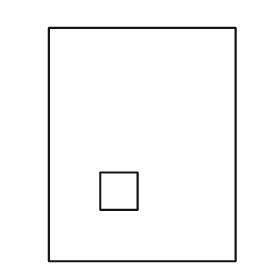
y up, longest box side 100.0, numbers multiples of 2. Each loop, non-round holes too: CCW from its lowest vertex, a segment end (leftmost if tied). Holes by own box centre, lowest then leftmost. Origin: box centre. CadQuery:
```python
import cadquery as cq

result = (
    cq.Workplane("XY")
    .moveTo(-40.0, -50.0)
    .lineTo(40.0, -50.0)
    .lineTo(40.0, 50.0)
    .lineTo(-40.0, 50.0)
    .close()
    .moveTo(-18.0, -28.0)
    .lineTo(-2.0, -28.0)
    .lineTo(-2.0, -12.0)
    .lineTo(-18.0, -12.0)
    .close()
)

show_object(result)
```